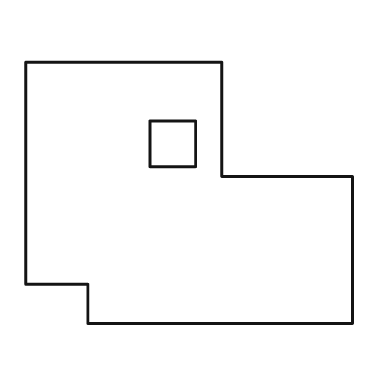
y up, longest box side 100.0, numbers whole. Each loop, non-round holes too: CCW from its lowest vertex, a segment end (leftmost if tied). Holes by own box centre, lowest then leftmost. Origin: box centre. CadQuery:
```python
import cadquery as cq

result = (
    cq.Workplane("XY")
    .moveTo(-31.0, -40.0)
    .lineTo(50.0, -40.0)
    .lineTo(50.0, 5.0)
    .lineTo(10.0, 5.0)
    .lineTo(10.0, 40.0)
    .lineTo(-50.0, 40.0)
    .lineTo(-50.0, -28.0)
    .lineTo(-31.0, -28.0)
    .close()
    .moveTo(-12.0, 8.0)
    .lineTo(2.0, 8.0)
    .lineTo(2.0, 22.0)
    .lineTo(-12.0, 22.0)
    .close()
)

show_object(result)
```